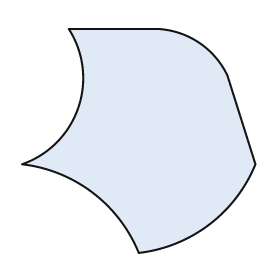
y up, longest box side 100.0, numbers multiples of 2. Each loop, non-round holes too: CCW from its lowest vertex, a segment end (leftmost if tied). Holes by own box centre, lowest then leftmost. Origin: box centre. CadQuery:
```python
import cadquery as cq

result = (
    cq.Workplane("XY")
    .moveTo(0.0, -48.0)
    .threePointArc((30.0, -36.0), (50.0, -10.0))
    .lineTo(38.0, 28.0)
    .threePointArc((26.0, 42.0), (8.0, 48.0))
    .lineTo(-30.0, 48.0)
    .threePointArc((-26.0, 14.0), (-50.0, -10.0))
    .threePointArc((-20.0, -22.0), (0.0, -48.0))
    .close()
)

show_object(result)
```